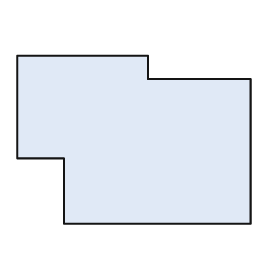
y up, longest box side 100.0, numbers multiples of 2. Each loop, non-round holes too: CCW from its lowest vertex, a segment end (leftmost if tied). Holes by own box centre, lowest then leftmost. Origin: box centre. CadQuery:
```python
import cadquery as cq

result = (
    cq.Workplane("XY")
    .moveTo(-30.0, -36.0)
    .lineTo(50.0, -36.0)
    .lineTo(50.0, 26.0)
    .lineTo(6.0, 26.0)
    .lineTo(6.0, 36.0)
    .lineTo(-50.0, 36.0)
    .lineTo(-50.0, -8.0)
    .lineTo(-30.0, -8.0)
    .close()
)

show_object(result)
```